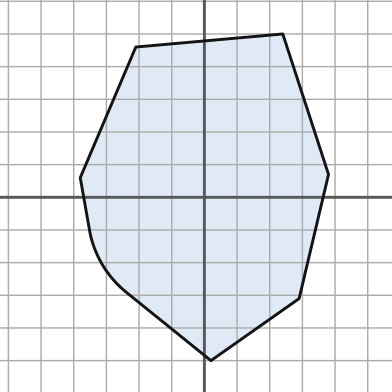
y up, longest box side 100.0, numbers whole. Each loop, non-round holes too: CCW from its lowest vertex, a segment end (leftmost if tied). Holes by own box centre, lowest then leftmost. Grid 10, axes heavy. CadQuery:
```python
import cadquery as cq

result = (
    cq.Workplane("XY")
    .moveTo(2.0, -50.0)
    .lineTo(29.0, -31.0)
    .lineTo(38.0, 7.0)
    .lineTo(24.0, 50.0)
    .lineTo(-21.0, 46.0)
    .lineTo(-38.0, 6.0)
    .lineTo(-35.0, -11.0)
    .threePointArc((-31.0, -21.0), (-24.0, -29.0))
    .close()
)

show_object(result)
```